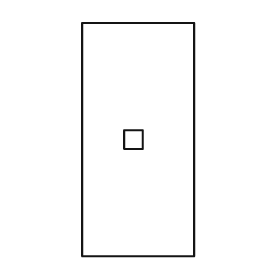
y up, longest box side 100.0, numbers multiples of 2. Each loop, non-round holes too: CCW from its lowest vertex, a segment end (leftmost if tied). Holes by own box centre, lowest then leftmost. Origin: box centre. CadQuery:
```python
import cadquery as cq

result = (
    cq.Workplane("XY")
    .moveTo(-24.0, -50.0)
    .lineTo(24.0, -50.0)
    .lineTo(24.0, 50.0)
    .lineTo(-24.0, 50.0)
    .close()
    .moveTo(-6.0, -4.0)
    .lineTo(2.0, -4.0)
    .lineTo(2.0, 4.0)
    .lineTo(-6.0, 4.0)
    .close()
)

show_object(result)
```